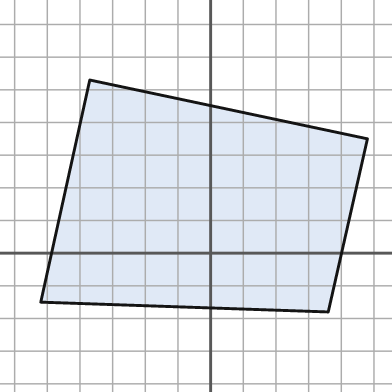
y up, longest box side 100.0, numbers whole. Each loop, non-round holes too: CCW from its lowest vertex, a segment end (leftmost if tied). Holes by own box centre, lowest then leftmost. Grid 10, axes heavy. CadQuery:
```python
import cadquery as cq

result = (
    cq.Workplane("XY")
    .moveTo(36.0, -18.0)
    .lineTo(48.0, 35.0)
    .lineTo(-37.0, 53.0)
    .lineTo(-52.0, -15.0)
    .close()
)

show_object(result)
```